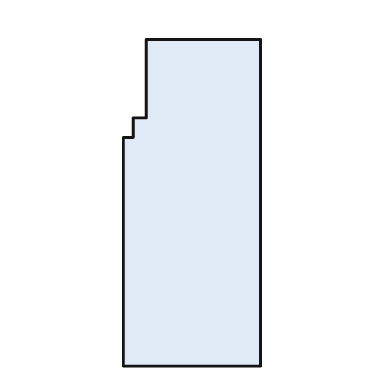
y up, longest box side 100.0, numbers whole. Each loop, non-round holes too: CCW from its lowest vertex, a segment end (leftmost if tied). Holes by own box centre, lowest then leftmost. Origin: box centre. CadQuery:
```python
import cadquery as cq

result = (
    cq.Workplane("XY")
    .moveTo(-21.0, -50.0)
    .lineTo(21.0, -50.0)
    .lineTo(21.0, 50.0)
    .lineTo(-14.0, 50.0)
    .lineTo(-14.0, 26.0)
    .lineTo(-18.0, 26.0)
    .lineTo(-18.0, 20.0)
    .lineTo(-21.0, 20.0)
    .close()
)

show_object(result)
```